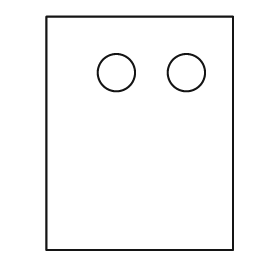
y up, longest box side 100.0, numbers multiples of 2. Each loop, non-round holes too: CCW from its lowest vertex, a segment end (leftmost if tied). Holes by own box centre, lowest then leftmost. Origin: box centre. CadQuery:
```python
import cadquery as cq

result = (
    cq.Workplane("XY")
    .moveTo(-40.0, -50.0)
    .lineTo(40.0, -50.0)
    .lineTo(40.0, 50.0)
    .lineTo(-40.0, 50.0)
    .close()
    .moveTo(-10.0, 26.0)
    .circle(8.0)
    .moveTo(20.0, 26.0)
    .circle(8.0)
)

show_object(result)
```